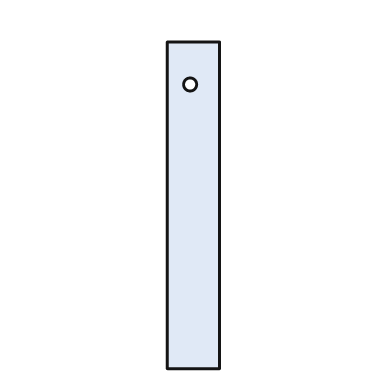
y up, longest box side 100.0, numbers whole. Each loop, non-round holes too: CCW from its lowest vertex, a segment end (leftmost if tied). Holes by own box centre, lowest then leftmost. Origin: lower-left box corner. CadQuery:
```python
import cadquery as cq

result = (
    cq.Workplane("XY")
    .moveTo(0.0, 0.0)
    .lineTo(16.0, 0.0)
    .lineTo(16.0, 100.0)
    .lineTo(0.0, 100.0)
    .close()
    .moveTo(7.0, 87.0)
    .circle(2.0)
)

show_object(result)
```